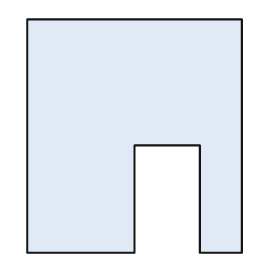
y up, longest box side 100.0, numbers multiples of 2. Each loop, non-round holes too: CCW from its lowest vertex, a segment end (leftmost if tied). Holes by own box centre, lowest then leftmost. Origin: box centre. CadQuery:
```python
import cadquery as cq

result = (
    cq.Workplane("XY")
    .moveTo(-46.0, -50.0)
    .lineTo(0.0, -50.0)
    .lineTo(0.0, -4.0)
    .lineTo(28.0, -4.0)
    .lineTo(28.0, -50.0)
    .lineTo(46.0, -50.0)
    .lineTo(46.0, 50.0)
    .lineTo(-46.0, 50.0)
    .close()
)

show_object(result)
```